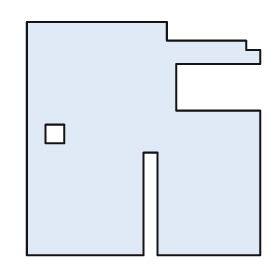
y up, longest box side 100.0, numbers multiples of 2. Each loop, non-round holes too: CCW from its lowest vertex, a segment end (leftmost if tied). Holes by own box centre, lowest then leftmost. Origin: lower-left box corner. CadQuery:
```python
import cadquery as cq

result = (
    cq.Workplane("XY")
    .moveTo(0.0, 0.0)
    .lineTo(50.0, 0.0)
    .lineTo(50.0, 44.0)
    .lineTo(56.0, 44.0)
    .lineTo(56.0, 0.0)
    .lineTo(100.0, 0.0)
    .lineTo(100.0, 62.0)
    .lineTo(64.0, 62.0)
    .lineTo(64.0, 82.0)
    .lineTo(100.0, 82.0)
    .lineTo(100.0, 88.0)
    .lineTo(94.0, 88.0)
    .lineTo(94.0, 92.0)
    .lineTo(60.0, 92.0)
    .lineTo(60.0, 100.0)
    .lineTo(0.0, 100.0)
    .close()
    .moveTo(8.0, 48.0)
    .lineTo(16.0, 48.0)
    .lineTo(16.0, 56.0)
    .lineTo(8.0, 56.0)
    .close()
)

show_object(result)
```